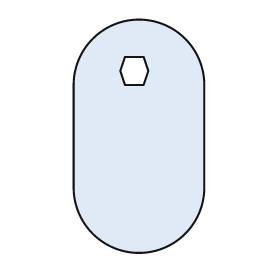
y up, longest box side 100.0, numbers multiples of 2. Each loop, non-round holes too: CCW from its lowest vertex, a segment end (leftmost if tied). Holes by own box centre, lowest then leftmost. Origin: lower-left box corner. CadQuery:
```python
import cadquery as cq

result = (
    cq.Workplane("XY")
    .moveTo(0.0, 28.0)
    .threePointArc((28.0, 0.0), (56.0, 28.0))
    .lineTo(56.0, 72.0)
    .threePointArc((28.0, 100.0), (0.0, 72.0))
    .close()
    .moveTo(22.0, 72.0)
    .lineTo(30.0, 72.0)
    .lineTo(32.0, 78.0)
    .lineTo(30.0, 84.0)
    .lineTo(22.0, 84.0)
    .lineTo(20.0, 78.0)
    .close()
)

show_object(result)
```